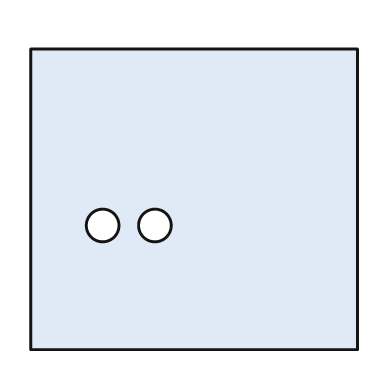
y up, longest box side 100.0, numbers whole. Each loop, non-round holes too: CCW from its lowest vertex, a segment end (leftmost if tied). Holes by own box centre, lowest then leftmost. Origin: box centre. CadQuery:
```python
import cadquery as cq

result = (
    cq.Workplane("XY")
    .moveTo(-50.0, -46.0)
    .lineTo(50.0, -46.0)
    .lineTo(50.0, 46.0)
    .lineTo(-50.0, 46.0)
    .close()
    .moveTo(-28.0, -8.0)
    .circle(5.0)
    .moveTo(-12.0, -8.0)
    .circle(5.0)
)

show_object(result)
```